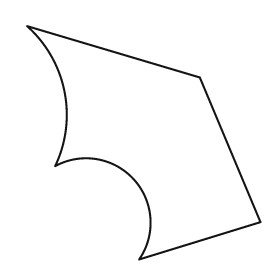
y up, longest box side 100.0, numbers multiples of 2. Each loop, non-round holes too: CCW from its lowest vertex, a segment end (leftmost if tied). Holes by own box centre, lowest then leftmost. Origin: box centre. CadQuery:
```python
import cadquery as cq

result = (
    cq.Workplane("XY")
    .moveTo(-2.0, -50.0)
    .lineTo(50.0, -34.0)
    .lineTo(24.0, 28.0)
    .lineTo(-50.0, 50.0)
    .threePointArc((-34.0, 22.0), (-38.0, -10.0))
    .threePointArc((-4.0, -16.0), (-2.0, -50.0))
    .close()
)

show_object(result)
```